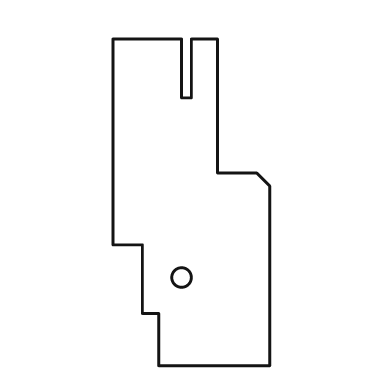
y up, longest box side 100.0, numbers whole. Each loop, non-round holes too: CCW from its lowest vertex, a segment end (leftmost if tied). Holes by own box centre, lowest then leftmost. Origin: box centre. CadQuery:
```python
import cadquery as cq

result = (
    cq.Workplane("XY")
    .moveTo(-10.0, -50.0)
    .lineTo(24.0, -50.0)
    .lineTo(24.0, 5.0)
    .lineTo(20.0, 9.0)
    .lineTo(8.0, 9.0)
    .lineTo(8.0, 50.0)
    .lineTo(0.0, 50.0)
    .lineTo(0.0, 32.0)
    .lineTo(-3.0, 32.0)
    .lineTo(-3.0, 50.0)
    .lineTo(-24.0, 50.0)
    .lineTo(-24.0, -13.0)
    .lineTo(-15.0, -13.0)
    .lineTo(-15.0, -34.0)
    .lineTo(-10.0, -34.0)
    .close()
    .moveTo(-3.0, -23.0)
    .circle(3.0)
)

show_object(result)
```